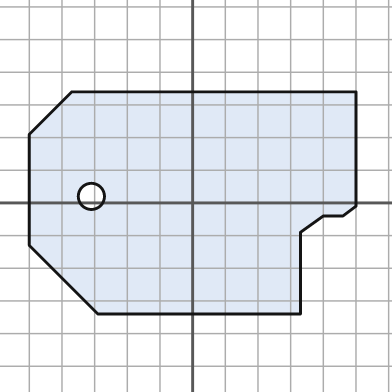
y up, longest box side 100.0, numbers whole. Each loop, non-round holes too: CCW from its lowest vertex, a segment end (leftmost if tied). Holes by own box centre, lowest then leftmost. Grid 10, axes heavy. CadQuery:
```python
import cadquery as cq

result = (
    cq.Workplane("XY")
    .moveTo(-29.0, -34.0)
    .lineTo(33.0, -34.0)
    .lineTo(33.0, -9.0)
    .lineTo(40.0, -4.0)
    .lineTo(46.0, -4.0)
    .lineTo(50.0, -1.0)
    .lineTo(50.0, 34.0)
    .lineTo(-37.0, 34.0)
    .lineTo(-50.0, 21.0)
    .lineTo(-50.0, -13.0)
    .close()
    .moveTo(-31.0, 2.0)
    .circle(4.0)
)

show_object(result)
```